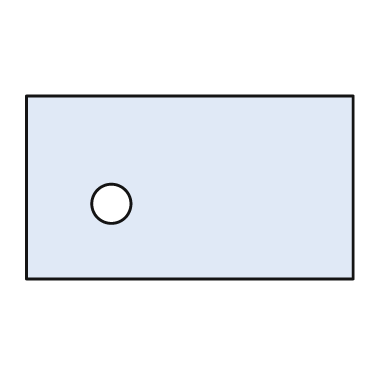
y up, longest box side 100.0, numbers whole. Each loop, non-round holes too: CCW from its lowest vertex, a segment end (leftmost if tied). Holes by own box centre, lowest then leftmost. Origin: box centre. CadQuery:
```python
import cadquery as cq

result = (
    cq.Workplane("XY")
    .moveTo(-50.0, -28.0)
    .lineTo(50.0, -28.0)
    .lineTo(50.0, 28.0)
    .lineTo(-50.0, 28.0)
    .close()
    .moveTo(-24.0, -5.0)
    .circle(6.0)
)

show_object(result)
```